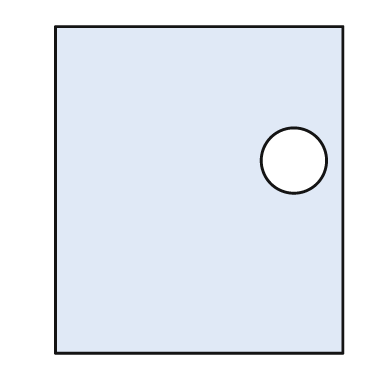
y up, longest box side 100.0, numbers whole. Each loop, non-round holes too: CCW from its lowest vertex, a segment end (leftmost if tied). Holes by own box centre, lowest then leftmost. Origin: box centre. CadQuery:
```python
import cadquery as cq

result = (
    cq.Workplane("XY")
    .moveTo(-44.0, -50.0)
    .lineTo(44.0, -50.0)
    .lineTo(44.0, 50.0)
    .lineTo(-44.0, 50.0)
    .close()
    .moveTo(29.0, 9.0)
    .circle(10.0)
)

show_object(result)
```